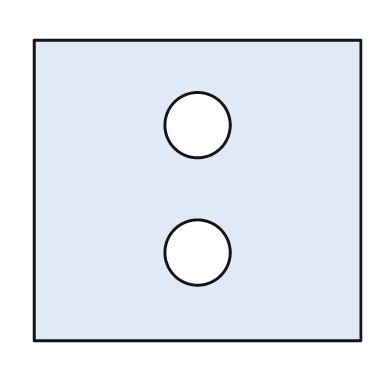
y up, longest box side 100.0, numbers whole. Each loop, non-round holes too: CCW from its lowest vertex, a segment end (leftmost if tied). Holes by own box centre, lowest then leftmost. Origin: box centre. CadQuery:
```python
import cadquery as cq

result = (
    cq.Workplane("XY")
    .moveTo(-50.0, -46.0)
    .lineTo(50.0, -46.0)
    .lineTo(50.0, 46.0)
    .lineTo(-50.0, 46.0)
    .close()
    .moveTo(0.0, -19.0)
    .circle(10.0)
    .moveTo(0.0, 20.0)
    .circle(10.0)
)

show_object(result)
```